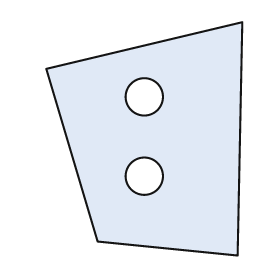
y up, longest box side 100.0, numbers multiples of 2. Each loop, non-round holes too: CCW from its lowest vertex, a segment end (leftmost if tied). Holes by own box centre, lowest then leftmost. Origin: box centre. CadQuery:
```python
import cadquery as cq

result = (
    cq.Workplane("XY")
    .moveTo(40.0, -50.0)
    .lineTo(42.0, 50.0)
    .lineTo(-42.0, 30.0)
    .lineTo(-20.0, -44.0)
    .close()
    .moveTo(0.0, -16.0)
    .circle(8.0)
    .moveTo(0.0, 18.0)
    .circle(8.0)
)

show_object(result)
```